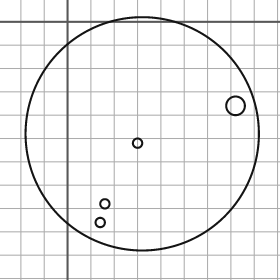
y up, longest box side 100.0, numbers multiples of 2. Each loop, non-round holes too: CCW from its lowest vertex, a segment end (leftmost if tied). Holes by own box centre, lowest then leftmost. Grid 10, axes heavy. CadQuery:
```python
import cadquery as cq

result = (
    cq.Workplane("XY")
    .moveTo(32.0, -48.0)
    .circle(50.0)
    .moveTo(14.0, -86.0)
    .circle(2.0)
    .moveTo(16.0, -78.0)
    .circle(2.0)
    .moveTo(30.0, -52.0)
    .circle(2.0)
    .moveTo(72.0, -36.0)
    .circle(4.0)
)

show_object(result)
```